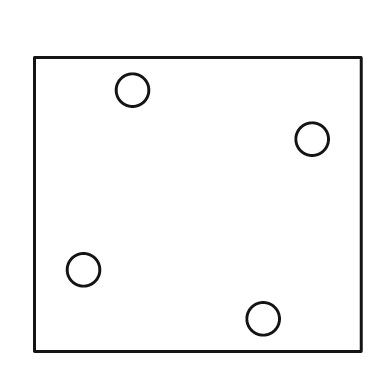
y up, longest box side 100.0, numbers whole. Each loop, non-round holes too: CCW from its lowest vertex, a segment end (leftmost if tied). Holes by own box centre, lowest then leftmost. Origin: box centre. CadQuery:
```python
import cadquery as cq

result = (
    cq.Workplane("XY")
    .moveTo(-50.0, -45.0)
    .lineTo(50.0, -45.0)
    .lineTo(50.0, 45.0)
    .lineTo(-50.0, 45.0)
    .close()
    .moveTo(20.0, -35.0)
    .circle(5.0)
    .moveTo(-35.0, -20.0)
    .circle(5.0)
    .moveTo(35.0, 20.0)
    .circle(5.0)
    .moveTo(-20.0, 35.0)
    .circle(5.0)
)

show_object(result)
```